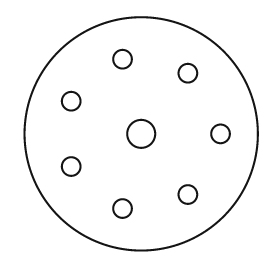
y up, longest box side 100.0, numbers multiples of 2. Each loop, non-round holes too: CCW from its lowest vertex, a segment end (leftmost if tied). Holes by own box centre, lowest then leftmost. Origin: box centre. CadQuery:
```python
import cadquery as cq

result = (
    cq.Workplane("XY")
    .moveTo(0.0, 0.0)
    .circle(50.0)
    .moveTo(-8.0, -32.0)
    .circle(4.0)
    .moveTo(20.0, -26.0)
    .circle(4.0)
    .moveTo(-30.0, -14.0)
    .circle(4.0)
    .moveTo(0.0, 0.0)
    .circle(6.0)
    .moveTo(34.0, 0.0)
    .circle(4.0)
    .moveTo(-30.0, 14.0)
    .circle(4.0)
    .moveTo(20.0, 26.0)
    .circle(4.0)
    .moveTo(-8.0, 32.0)
    .circle(4.0)
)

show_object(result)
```